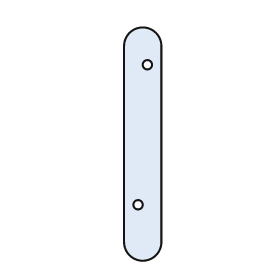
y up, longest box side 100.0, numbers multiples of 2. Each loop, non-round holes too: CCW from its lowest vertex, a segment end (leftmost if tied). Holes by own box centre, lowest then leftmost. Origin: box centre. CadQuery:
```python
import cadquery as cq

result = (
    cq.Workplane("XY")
    .moveTo(-8.0, -42.0)
    .threePointArc((0.0, -50.0), (8.0, -42.0))
    .lineTo(8.0, 42.0)
    .threePointArc((0.0, 50.0), (-8.0, 42.0))
    .close()
    .moveTo(-2.0, -26.0)
    .circle(2.0)
    .moveTo(2.0, 34.0)
    .circle(2.0)
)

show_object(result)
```